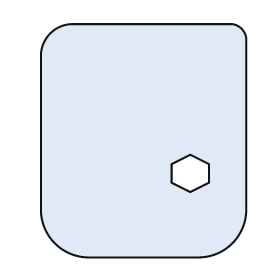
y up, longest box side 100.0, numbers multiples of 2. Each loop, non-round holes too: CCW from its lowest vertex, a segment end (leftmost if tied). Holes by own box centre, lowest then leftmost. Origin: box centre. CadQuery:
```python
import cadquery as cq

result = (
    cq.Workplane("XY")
    .moveTo(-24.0, -50.0)
    .lineTo(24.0, -50.0)
    .threePointArc((38.0, -44.0), (44.0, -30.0))
    .lineTo(44.0, 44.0)
    .threePointArc((42.0, 48.0), (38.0, 50.0))
    .lineTo(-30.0, 50.0)
    .threePointArc((-40.0, 46.0), (-44.0, 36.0))
    .lineTo(-44.0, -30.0)
    .threePointArc((-38.0, -44.0), (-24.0, -50.0))
    .close()
    .moveTo(20.0, -22.0)
    .lineTo(28.0, -18.0)
    .lineTo(28.0, -10.0)
    .lineTo(20.0, -6.0)
    .lineTo(12.0, -10.0)
    .lineTo(12.0, -18.0)
    .close()
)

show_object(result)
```